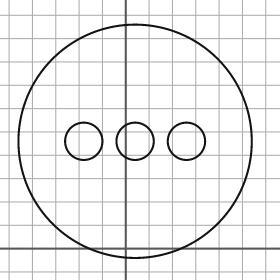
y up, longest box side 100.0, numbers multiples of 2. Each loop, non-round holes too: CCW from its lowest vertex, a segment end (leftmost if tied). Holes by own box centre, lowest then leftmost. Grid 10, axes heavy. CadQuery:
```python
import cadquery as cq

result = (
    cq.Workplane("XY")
    .moveTo(4.0, 46.0)
    .circle(50.0)
    .moveTo(-18.0, 46.0)
    .circle(8.0)
    .moveTo(4.0, 46.0)
    .circle(8.0)
    .moveTo(26.0, 46.0)
    .circle(8.0)
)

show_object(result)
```